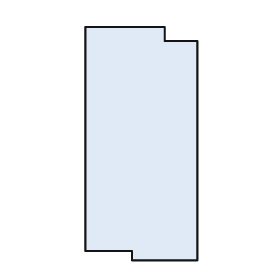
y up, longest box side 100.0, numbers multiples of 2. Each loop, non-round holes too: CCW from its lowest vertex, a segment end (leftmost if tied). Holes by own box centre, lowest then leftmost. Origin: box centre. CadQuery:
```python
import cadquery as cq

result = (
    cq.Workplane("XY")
    .moveTo(-4.0, -50.0)
    .lineTo(24.0, -50.0)
    .lineTo(24.0, 44.0)
    .lineTo(10.0, 44.0)
    .lineTo(10.0, 50.0)
    .lineTo(-24.0, 50.0)
    .lineTo(-24.0, -46.0)
    .lineTo(-4.0, -46.0)
    .close()
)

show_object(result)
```